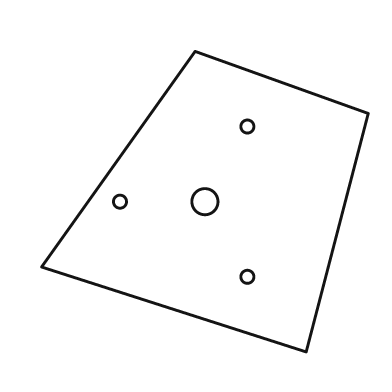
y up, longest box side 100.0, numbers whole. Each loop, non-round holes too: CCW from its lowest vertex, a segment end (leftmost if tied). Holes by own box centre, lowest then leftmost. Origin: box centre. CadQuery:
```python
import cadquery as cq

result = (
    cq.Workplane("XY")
    .moveTo(31.0, -46.0)
    .lineTo(50.0, 27.0)
    .lineTo(-3.0, 46.0)
    .lineTo(-50.0, -20.0)
    .close()
    .moveTo(13.0, -23.0)
    .circle(2.0)
    .moveTo(-26.0, 0.0)
    .circle(2.0)
    .moveTo(0.0, 0.0)
    .circle(4.0)
    .moveTo(13.0, 23.0)
    .circle(2.0)
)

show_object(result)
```